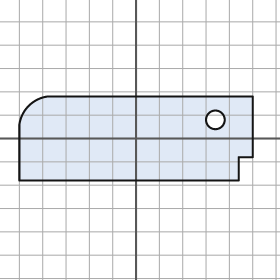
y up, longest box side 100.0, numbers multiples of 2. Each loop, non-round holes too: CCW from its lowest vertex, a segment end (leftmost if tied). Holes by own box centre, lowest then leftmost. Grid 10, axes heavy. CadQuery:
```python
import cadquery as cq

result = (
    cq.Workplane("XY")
    .moveTo(-50.0, -18.0)
    .lineTo(44.0, -18.0)
    .lineTo(44.0, -8.0)
    .lineTo(50.0, -8.0)
    .lineTo(50.0, 18.0)
    .lineTo(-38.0, 18.0)
    .threePointArc((-46.0, 14.0), (-50.0, 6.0))
    .close()
    .moveTo(34.0, 8.0)
    .circle(4.0)
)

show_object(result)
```